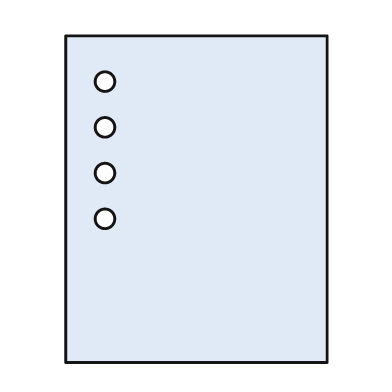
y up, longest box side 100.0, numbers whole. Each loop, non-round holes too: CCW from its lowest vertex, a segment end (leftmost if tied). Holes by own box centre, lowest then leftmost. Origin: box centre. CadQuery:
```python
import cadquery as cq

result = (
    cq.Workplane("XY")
    .moveTo(-40.0, -50.0)
    .lineTo(40.0, -50.0)
    .lineTo(40.0, 50.0)
    .lineTo(-40.0, 50.0)
    .close()
    .moveTo(-28.0, -6.0)
    .circle(3.0)
    .moveTo(-28.0, 8.0)
    .circle(3.0)
    .moveTo(-28.0, 22.0)
    .circle(3.0)
    .moveTo(-28.0, 36.0)
    .circle(3.0)
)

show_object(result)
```